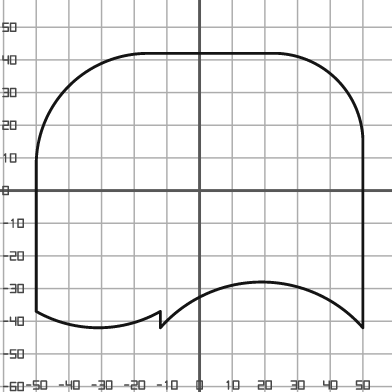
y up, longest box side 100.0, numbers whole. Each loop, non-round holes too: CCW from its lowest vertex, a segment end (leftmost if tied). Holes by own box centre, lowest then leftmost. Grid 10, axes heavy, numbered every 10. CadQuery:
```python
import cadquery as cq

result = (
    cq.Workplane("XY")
    .moveTo(-12.0, -42.0)
    .threePointArc((19.0, -28.0), (50.0, -42.0))
    .lineTo(50.0, 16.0)
    .threePointArc((42.0, 34.0), (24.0, 42.0))
    .lineTo(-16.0, 42.0)
    .threePointArc((-40.0, 32.0), (-50.0, 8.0))
    .lineTo(-50.0, -37.0)
    .threePointArc((-31.0, -42.0), (-12.0, -37.0))
    .close()
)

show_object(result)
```